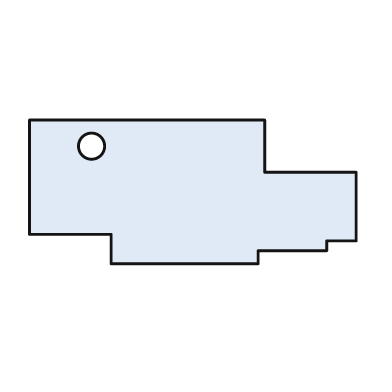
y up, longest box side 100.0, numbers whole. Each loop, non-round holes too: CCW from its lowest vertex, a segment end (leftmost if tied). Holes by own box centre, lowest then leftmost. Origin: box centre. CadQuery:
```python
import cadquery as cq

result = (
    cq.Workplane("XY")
    .moveTo(-25.0, -22.0)
    .lineTo(20.0, -22.0)
    .lineTo(20.0, -18.0)
    .lineTo(41.0, -18.0)
    .lineTo(41.0, -15.0)
    .lineTo(50.0, -15.0)
    .lineTo(50.0, 6.0)
    .lineTo(22.0, 6.0)
    .lineTo(22.0, 22.0)
    .lineTo(-50.0, 22.0)
    .lineTo(-50.0, -13.0)
    .lineTo(-25.0, -13.0)
    .close()
    .moveTo(-31.0, 14.0)
    .circle(4.0)
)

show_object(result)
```